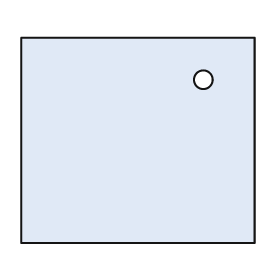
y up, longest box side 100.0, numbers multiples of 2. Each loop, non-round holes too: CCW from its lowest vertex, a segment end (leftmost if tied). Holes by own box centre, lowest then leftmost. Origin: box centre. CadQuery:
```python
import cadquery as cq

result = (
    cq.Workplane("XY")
    .moveTo(-50.0, -44.0)
    .lineTo(50.0, -44.0)
    .lineTo(50.0, 44.0)
    .lineTo(-50.0, 44.0)
    .close()
    .moveTo(28.0, 26.0)
    .circle(4.0)
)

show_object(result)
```